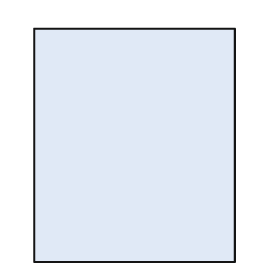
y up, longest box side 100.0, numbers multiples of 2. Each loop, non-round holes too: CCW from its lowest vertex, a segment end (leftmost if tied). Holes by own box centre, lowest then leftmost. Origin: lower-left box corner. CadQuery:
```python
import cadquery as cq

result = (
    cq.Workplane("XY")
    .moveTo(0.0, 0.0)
    .lineTo(86.0, 0.0)
    .lineTo(86.0, 100.0)
    .lineTo(0.0, 100.0)
    .close()
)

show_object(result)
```